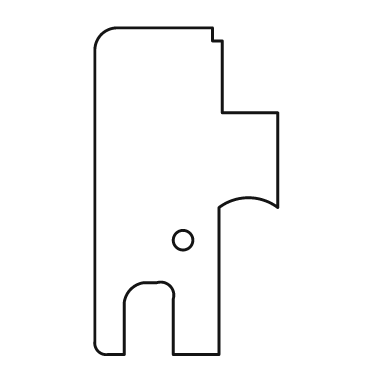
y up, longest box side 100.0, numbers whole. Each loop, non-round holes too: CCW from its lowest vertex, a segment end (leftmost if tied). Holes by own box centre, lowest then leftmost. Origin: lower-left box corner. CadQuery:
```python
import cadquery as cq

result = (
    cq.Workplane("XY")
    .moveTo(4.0, 0.0)
    .lineTo(9.0, 0.0)
    .lineTo(9.0, 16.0)
    .threePointArc((11.0, 20.0), (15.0, 22.0))
    .lineTo(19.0, 22.0)
    .threePointArc((23.0, 21.0), (24.0, 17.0))
    .lineTo(24.0, 0.0)
    .lineTo(38.0, 0.0)
    .lineTo(38.0, 45.0)
    .threePointArc((47.0, 48.0), (56.0, 45.0))
    .lineTo(56.0, 74.0)
    .lineTo(39.0, 74.0)
    .lineTo(39.0, 96.0)
    .lineTo(36.0, 96.0)
    .lineTo(36.0, 100.0)
    .lineTo(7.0, 100.0)
    .threePointArc((2.0, 98.0), (0.0, 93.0))
    .lineTo(0.0, 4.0)
    .threePointArc((1.0, 1.0), (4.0, 0.0))
    .close()
    .moveTo(27.0, 35.0)
    .circle(3.0)
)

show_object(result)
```